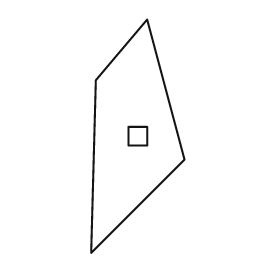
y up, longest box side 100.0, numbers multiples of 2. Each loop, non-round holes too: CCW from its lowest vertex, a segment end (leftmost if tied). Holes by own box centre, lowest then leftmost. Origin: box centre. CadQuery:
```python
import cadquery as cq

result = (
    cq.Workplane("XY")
    .moveTo(-20.0, -50.0)
    .lineTo(20.0, -10.0)
    .lineTo(4.0, 50.0)
    .lineTo(-18.0, 24.0)
    .close()
    .moveTo(-4.0, -4.0)
    .lineTo(4.0, -4.0)
    .lineTo(4.0, 4.0)
    .lineTo(-4.0, 4.0)
    .close()
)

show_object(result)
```